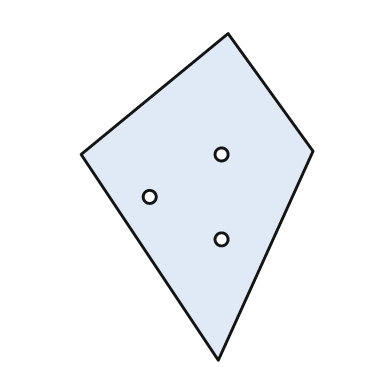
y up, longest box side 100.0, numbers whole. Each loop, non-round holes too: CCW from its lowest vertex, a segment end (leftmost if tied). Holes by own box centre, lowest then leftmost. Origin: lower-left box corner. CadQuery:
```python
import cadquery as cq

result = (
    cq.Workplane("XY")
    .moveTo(42.0, 0.0)
    .lineTo(71.0, 64.0)
    .lineTo(45.0, 100.0)
    .lineTo(0.0, 63.0)
    .close()
    .moveTo(43.0, 37.0)
    .circle(2.0)
    .moveTo(21.0, 50.0)
    .circle(2.0)
    .moveTo(43.0, 63.0)
    .circle(2.0)
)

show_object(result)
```